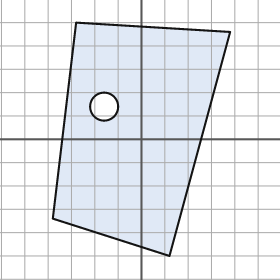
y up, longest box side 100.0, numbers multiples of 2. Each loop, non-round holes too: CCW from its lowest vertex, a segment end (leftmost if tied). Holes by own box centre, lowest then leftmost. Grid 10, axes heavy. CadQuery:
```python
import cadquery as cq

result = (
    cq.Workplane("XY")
    .moveTo(12.0, -50.0)
    .lineTo(38.0, 46.0)
    .lineTo(-28.0, 50.0)
    .lineTo(-38.0, -34.0)
    .close()
    .moveTo(-16.0, 14.0)
    .circle(6.0)
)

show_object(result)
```